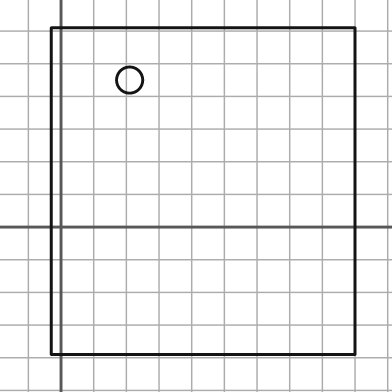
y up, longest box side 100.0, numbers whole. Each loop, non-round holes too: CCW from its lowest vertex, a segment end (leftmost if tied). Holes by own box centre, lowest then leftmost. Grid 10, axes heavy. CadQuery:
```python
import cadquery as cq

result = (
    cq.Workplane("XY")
    .moveTo(-3.0, -39.0)
    .lineTo(90.0, -39.0)
    .lineTo(90.0, 61.0)
    .lineTo(-3.0, 61.0)
    .close()
    .moveTo(21.0, 45.0)
    .circle(4.0)
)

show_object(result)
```